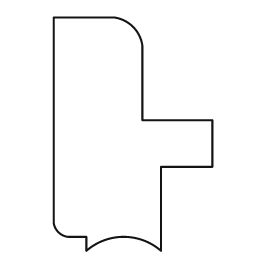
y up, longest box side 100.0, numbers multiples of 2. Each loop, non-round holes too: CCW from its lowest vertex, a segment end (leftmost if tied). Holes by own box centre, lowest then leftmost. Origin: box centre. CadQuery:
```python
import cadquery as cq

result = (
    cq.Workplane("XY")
    .moveTo(-20.0, -50.0)
    .threePointArc((-4.0, -44.0), (12.0, -50.0))
    .lineTo(12.0, -14.0)
    .lineTo(34.0, -14.0)
    .lineTo(34.0, 6.0)
    .lineTo(4.0, 6.0)
    .lineTo(4.0, 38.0)
    .threePointArc((0.0, 46.0), (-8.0, 50.0))
    .lineTo(-34.0, 50.0)
    .lineTo(-34.0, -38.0)
    .threePointArc((-32.0, -42.0), (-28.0, -44.0))
    .lineTo(-20.0, -44.0)
    .close()
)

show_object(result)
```